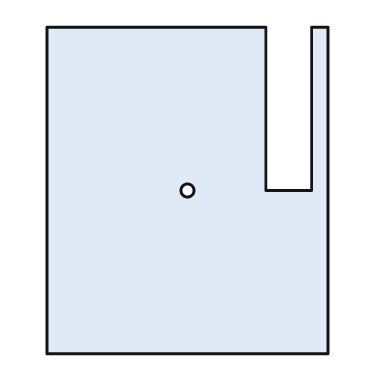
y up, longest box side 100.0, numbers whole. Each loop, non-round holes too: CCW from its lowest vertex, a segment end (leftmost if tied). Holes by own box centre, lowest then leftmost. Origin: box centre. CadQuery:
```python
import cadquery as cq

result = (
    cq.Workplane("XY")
    .moveTo(-43.0, -50.0)
    .lineTo(43.0, -50.0)
    .lineTo(43.0, 50.0)
    .lineTo(38.0, 50.0)
    .lineTo(38.0, 0.0)
    .lineTo(24.0, 0.0)
    .lineTo(24.0, 50.0)
    .lineTo(-43.0, 50.0)
    .close()
    .moveTo(0.0, 0.0)
    .circle(2.0)
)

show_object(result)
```